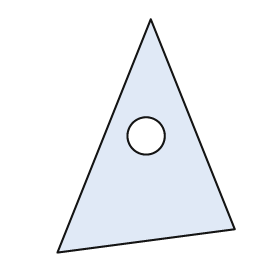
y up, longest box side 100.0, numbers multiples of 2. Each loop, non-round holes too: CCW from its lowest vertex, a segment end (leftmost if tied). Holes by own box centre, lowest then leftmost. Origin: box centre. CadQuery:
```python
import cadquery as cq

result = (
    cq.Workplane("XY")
    .moveTo(-38.0, -50.0)
    .lineTo(38.0, -40.0)
    .lineTo(2.0, 50.0)
    .close()
    .moveTo(0.0, 0.0)
    .circle(8.0)
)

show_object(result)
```